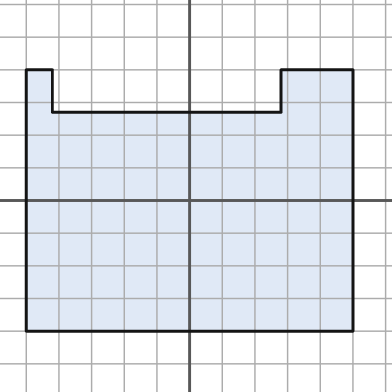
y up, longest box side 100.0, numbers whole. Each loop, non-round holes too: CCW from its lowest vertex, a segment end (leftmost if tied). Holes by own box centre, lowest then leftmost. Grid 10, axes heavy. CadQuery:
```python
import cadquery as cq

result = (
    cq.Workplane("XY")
    .moveTo(-50.0, -40.0)
    .lineTo(50.0, -40.0)
    .lineTo(50.0, 40.0)
    .lineTo(28.0, 40.0)
    .lineTo(28.0, 27.0)
    .lineTo(-42.0, 27.0)
    .lineTo(-42.0, 40.0)
    .lineTo(-50.0, 40.0)
    .close()
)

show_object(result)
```